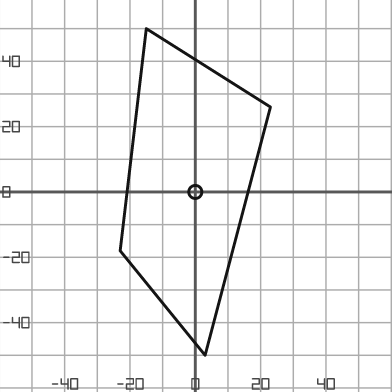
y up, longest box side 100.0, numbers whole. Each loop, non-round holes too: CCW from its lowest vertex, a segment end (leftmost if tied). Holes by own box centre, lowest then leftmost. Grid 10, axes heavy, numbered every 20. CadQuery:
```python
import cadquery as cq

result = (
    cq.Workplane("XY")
    .moveTo(3.0, -50.0)
    .lineTo(23.0, 26.0)
    .lineTo(-15.0, 50.0)
    .lineTo(-23.0, -18.0)
    .close()
    .moveTo(0.0, 0.0)
    .circle(2.0)
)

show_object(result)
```